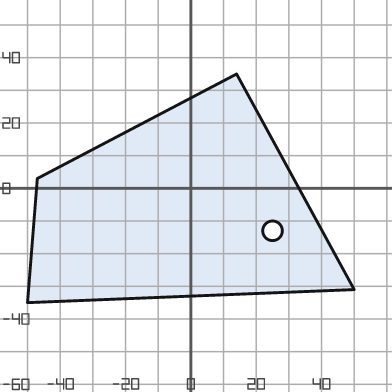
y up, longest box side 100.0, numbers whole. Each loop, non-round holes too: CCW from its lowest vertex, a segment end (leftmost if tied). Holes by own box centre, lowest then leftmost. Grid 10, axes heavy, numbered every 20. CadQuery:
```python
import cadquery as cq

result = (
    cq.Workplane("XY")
    .moveTo(-50.0, -35.0)
    .lineTo(50.0, -31.0)
    .lineTo(14.0, 35.0)
    .lineTo(-47.0, 3.0)
    .close()
    .moveTo(25.0, -13.0)
    .circle(3.0)
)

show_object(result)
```